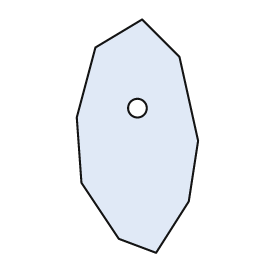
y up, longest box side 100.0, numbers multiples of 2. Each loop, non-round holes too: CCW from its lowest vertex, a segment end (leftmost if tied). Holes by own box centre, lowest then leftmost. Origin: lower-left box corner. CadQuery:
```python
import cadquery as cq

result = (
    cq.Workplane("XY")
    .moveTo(34.0, 0.0)
    .lineTo(48.0, 22.0)
    .lineTo(52.0, 48.0)
    .lineTo(44.0, 84.0)
    .lineTo(28.0, 100.0)
    .lineTo(8.0, 88.0)
    .lineTo(0.0, 58.0)
    .lineTo(2.0, 30.0)
    .lineTo(18.0, 6.0)
    .close()
    .moveTo(26.0, 62.0)
    .circle(4.0)
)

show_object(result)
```